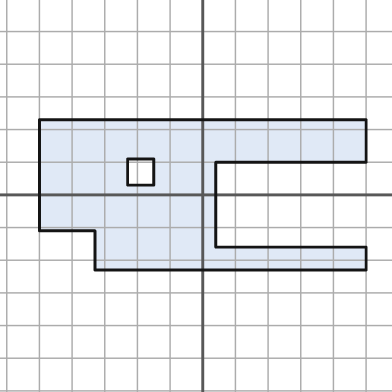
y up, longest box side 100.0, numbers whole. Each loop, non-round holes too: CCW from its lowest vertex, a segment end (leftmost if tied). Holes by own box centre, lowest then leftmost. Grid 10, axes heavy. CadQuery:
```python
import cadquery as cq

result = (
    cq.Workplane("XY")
    .moveTo(-33.0, -23.0)
    .lineTo(50.0, -23.0)
    .lineTo(50.0, -16.0)
    .lineTo(4.0, -16.0)
    .lineTo(4.0, 10.0)
    .lineTo(50.0, 10.0)
    .lineTo(50.0, 23.0)
    .lineTo(-50.0, 23.0)
    .lineTo(-50.0, -11.0)
    .lineTo(-33.0, -11.0)
    .close()
    .moveTo(-23.0, 3.0)
    .lineTo(-15.0, 3.0)
    .lineTo(-15.0, 11.0)
    .lineTo(-23.0, 11.0)
    .close()
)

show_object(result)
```